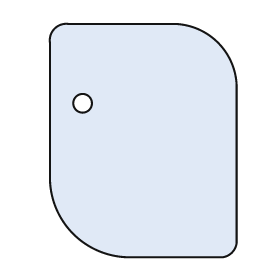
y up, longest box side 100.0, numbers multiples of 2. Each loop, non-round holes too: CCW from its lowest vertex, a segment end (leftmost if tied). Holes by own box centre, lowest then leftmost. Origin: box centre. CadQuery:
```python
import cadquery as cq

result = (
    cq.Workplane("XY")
    .moveTo(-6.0, -50.0)
    .lineTo(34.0, -50.0)
    .threePointArc((38.0, -48.0), (40.0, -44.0))
    .lineTo(40.0, 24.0)
    .threePointArc((32.0, 42.0), (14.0, 50.0))
    .lineTo(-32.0, 50.0)
    .threePointArc((-38.0, 48.0), (-40.0, 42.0))
    .lineTo(-40.0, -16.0)
    .threePointArc((-30.0, -40.0), (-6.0, -50.0))
    .close()
    .moveTo(-26.0, 16.0)
    .circle(4.0)
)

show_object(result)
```